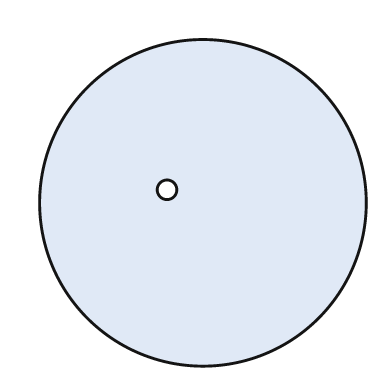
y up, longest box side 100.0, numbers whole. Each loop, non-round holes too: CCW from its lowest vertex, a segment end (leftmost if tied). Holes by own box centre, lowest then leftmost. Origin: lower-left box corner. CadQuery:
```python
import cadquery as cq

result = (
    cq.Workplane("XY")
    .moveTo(50.0, 50.0)
    .circle(50.0)
    .moveTo(39.0, 54.0)
    .circle(3.0)
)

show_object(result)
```